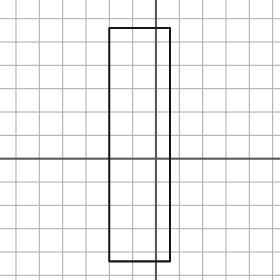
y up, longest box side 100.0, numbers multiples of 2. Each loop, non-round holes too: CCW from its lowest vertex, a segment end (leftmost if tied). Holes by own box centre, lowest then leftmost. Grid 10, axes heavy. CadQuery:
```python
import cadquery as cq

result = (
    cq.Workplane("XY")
    .moveTo(-20.0, -44.0)
    .lineTo(6.0, -44.0)
    .lineTo(6.0, 56.0)
    .lineTo(-20.0, 56.0)
    .close()
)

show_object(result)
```